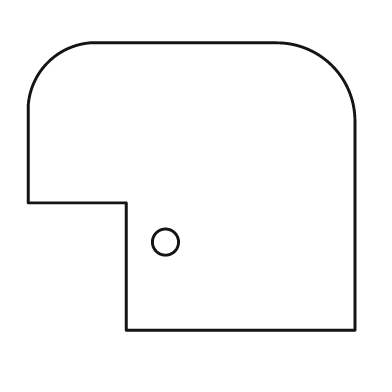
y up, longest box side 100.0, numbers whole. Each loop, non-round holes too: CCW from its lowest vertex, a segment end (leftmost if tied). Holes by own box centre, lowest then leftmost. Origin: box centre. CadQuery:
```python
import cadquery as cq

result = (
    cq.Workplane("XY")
    .moveTo(-20.0, -44.0)
    .lineTo(50.0, -44.0)
    .lineTo(50.0, 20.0)
    .threePointArc((43.0, 37.0), (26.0, 44.0))
    .lineTo(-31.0, 44.0)
    .threePointArc((-44.0, 38.0), (-50.0, 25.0))
    .lineTo(-50.0, -5.0)
    .lineTo(-20.0, -5.0)
    .close()
    .moveTo(-8.0, -17.0)
    .circle(4.0)
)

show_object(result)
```